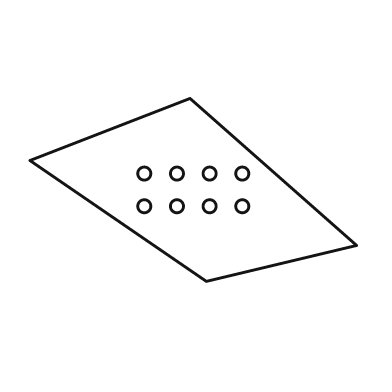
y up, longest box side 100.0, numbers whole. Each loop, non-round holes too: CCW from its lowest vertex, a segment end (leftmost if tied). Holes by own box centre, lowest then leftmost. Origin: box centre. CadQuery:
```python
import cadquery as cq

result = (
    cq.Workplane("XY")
    .moveTo(4.0, -28.0)
    .lineTo(50.0, -17.0)
    .lineTo(-1.0, 28.0)
    .lineTo(-50.0, 9.0)
    .close()
    .moveTo(-15.0, -5.0)
    .circle(2.0)
    .moveTo(-5.0, -5.0)
    .circle(2.0)
    .moveTo(5.0, -5.0)
    .circle(2.0)
    .moveTo(15.0, -5.0)
    .circle(2.0)
    .moveTo(-15.0, 5.0)
    .circle(2.0)
    .moveTo(-5.0, 5.0)
    .circle(2.0)
    .moveTo(5.0, 5.0)
    .circle(2.0)
    .moveTo(15.0, 5.0)
    .circle(2.0)
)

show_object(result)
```